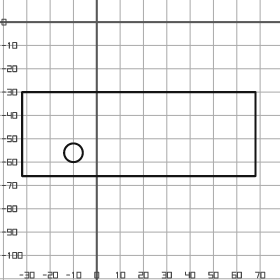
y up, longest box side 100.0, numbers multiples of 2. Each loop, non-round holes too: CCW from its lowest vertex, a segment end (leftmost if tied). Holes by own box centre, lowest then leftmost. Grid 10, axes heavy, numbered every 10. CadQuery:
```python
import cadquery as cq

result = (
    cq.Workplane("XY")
    .moveTo(-32.0, -66.0)
    .lineTo(68.0, -66.0)
    .lineTo(68.0, -30.0)
    .lineTo(-32.0, -30.0)
    .close()
    .moveTo(-10.0, -56.0)
    .circle(4.0)
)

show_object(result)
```